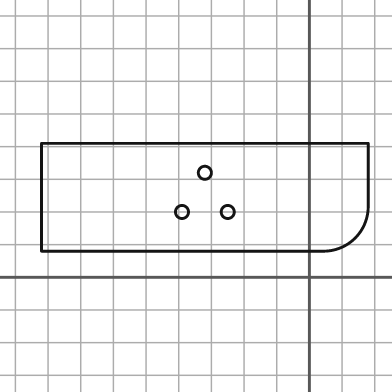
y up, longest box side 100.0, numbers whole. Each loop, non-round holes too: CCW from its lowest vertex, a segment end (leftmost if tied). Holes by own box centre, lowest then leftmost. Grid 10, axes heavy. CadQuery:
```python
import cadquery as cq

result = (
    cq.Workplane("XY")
    .moveTo(-82.0, 8.0)
    .lineTo(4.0, 8.0)
    .threePointArc((14.0, 12.0), (18.0, 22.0))
    .lineTo(18.0, 41.0)
    .lineTo(-82.0, 41.0)
    .close()
    .moveTo(-39.0, 20.0)
    .circle(2.0)
    .moveTo(-25.0, 20.0)
    .circle(2.0)
    .moveTo(-32.0, 32.0)
    .circle(2.0)
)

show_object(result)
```